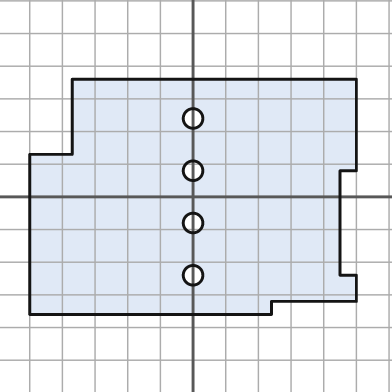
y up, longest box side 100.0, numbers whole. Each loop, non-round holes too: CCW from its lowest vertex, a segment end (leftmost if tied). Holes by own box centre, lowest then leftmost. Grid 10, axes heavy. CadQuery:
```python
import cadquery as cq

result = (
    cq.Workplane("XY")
    .moveTo(-50.0, -36.0)
    .lineTo(24.0, -36.0)
    .lineTo(24.0, -32.0)
    .lineTo(50.0, -32.0)
    .lineTo(50.0, -24.0)
    .lineTo(45.0, -24.0)
    .lineTo(45.0, 8.0)
    .lineTo(50.0, 8.0)
    .lineTo(50.0, 36.0)
    .lineTo(-37.0, 36.0)
    .lineTo(-37.0, 13.0)
    .lineTo(-50.0, 13.0)
    .close()
    .moveTo(0.0, -24.0)
    .circle(3.0)
    .moveTo(0.0, -8.0)
    .circle(3.0)
    .moveTo(0.0, 8.0)
    .circle(3.0)
    .moveTo(0.0, 24.0)
    .circle(3.0)
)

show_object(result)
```